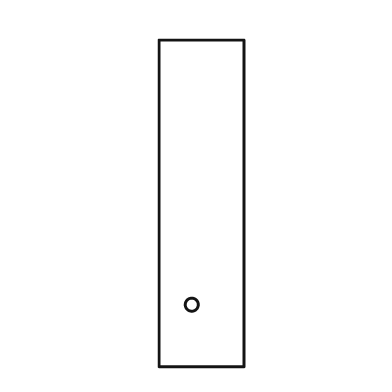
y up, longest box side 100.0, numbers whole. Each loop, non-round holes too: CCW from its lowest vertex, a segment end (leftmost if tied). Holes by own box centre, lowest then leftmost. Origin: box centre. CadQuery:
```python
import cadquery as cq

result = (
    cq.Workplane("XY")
    .moveTo(-13.0, -50.0)
    .lineTo(13.0, -50.0)
    .lineTo(13.0, 50.0)
    .lineTo(-13.0, 50.0)
    .close()
    .moveTo(-3.0, -31.0)
    .circle(2.0)
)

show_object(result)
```